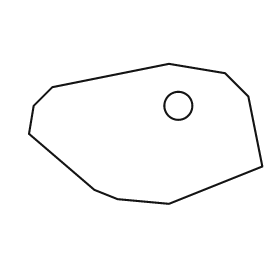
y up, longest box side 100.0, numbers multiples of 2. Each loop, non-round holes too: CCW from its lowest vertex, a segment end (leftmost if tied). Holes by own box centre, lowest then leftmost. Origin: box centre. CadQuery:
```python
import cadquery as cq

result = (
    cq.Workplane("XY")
    .moveTo(10.0, -30.0)
    .lineTo(50.0, -14.0)
    .lineTo(44.0, 16.0)
    .lineTo(34.0, 26.0)
    .lineTo(10.0, 30.0)
    .lineTo(-40.0, 20.0)
    .lineTo(-48.0, 12.0)
    .lineTo(-50.0, 0.0)
    .lineTo(-22.0, -24.0)
    .lineTo(-12.0, -28.0)
    .close()
    .moveTo(14.0, 12.0)
    .circle(6.0)
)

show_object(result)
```